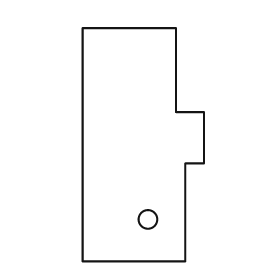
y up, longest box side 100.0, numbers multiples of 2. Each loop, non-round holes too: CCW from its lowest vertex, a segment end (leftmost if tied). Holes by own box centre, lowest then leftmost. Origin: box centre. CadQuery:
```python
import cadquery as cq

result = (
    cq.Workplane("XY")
    .moveTo(-26.0, -50.0)
    .lineTo(18.0, -50.0)
    .lineTo(18.0, -8.0)
    .lineTo(26.0, -8.0)
    .lineTo(26.0, 14.0)
    .lineTo(14.0, 14.0)
    .lineTo(14.0, 50.0)
    .lineTo(-26.0, 50.0)
    .close()
    .moveTo(2.0, -32.0)
    .circle(4.0)
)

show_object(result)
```